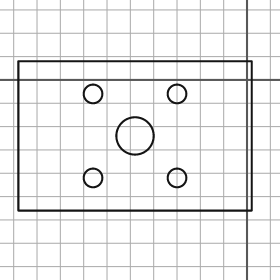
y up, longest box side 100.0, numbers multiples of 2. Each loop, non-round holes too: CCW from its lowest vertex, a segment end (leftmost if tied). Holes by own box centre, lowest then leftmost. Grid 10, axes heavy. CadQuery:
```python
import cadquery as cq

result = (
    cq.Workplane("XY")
    .moveTo(-98.0, -56.0)
    .lineTo(2.0, -56.0)
    .lineTo(2.0, 8.0)
    .lineTo(-98.0, 8.0)
    .close()
    .moveTo(-66.0, -42.0)
    .circle(4.0)
    .moveTo(-30.0, -42.0)
    .circle(4.0)
    .moveTo(-48.0, -24.0)
    .circle(8.0)
    .moveTo(-66.0, -6.0)
    .circle(4.0)
    .moveTo(-30.0, -6.0)
    .circle(4.0)
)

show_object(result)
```